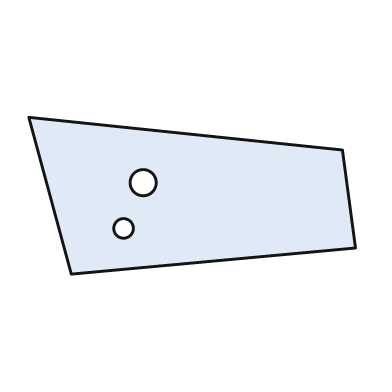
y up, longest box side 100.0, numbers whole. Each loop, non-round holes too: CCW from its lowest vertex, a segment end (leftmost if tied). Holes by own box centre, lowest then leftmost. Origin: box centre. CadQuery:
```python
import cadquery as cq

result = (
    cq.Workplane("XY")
    .moveTo(-37.0, -24.0)
    .lineTo(50.0, -16.0)
    .lineTo(46.0, 14.0)
    .lineTo(-50.0, 24.0)
    .close()
    .moveTo(-21.0, -10.0)
    .circle(3.0)
    .moveTo(-15.0, 4.0)
    .circle(4.0)
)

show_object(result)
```